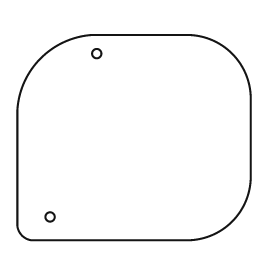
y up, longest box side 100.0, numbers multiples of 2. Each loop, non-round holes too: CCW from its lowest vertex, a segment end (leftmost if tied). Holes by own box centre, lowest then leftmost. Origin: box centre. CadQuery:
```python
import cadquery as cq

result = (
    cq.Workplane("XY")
    .moveTo(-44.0, -44.0)
    .lineTo(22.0, -44.0)
    .threePointArc((42.0, -36.0), (50.0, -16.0))
    .lineTo(50.0, 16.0)
    .threePointArc((42.0, 36.0), (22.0, 44.0))
    .lineTo(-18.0, 44.0)
    .threePointArc((-40.0, 34.0), (-50.0, 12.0))
    .lineTo(-50.0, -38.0)
    .threePointArc((-48.0, -42.0), (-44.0, -44.0))
    .close()
    .moveTo(-36.0, -34.0)
    .circle(2.0)
    .moveTo(-16.0, 36.0)
    .circle(2.0)
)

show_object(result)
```